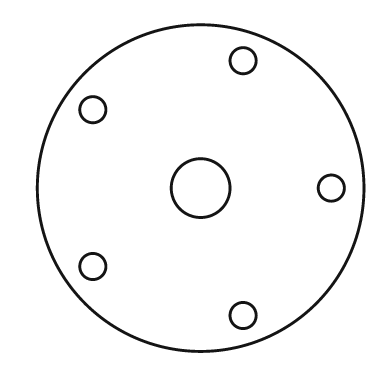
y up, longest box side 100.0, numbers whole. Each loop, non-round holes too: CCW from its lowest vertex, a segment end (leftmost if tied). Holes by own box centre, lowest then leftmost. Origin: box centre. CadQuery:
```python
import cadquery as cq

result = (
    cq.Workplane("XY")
    .moveTo(0.0, 0.0)
    .circle(50.0)
    .moveTo(13.0, -39.0)
    .circle(4.0)
    .moveTo(-33.0, -24.0)
    .circle(4.0)
    .moveTo(0.0, 0.0)
    .circle(9.0)
    .moveTo(40.0, 0.0)
    .circle(4.0)
    .moveTo(-33.0, 24.0)
    .circle(4.0)
    .moveTo(13.0, 39.0)
    .circle(4.0)
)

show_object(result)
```